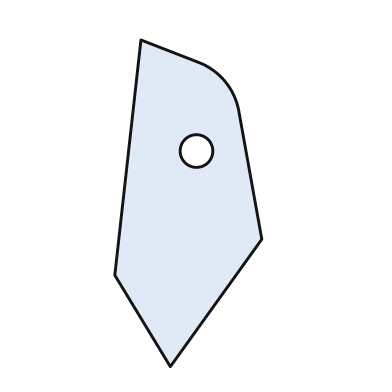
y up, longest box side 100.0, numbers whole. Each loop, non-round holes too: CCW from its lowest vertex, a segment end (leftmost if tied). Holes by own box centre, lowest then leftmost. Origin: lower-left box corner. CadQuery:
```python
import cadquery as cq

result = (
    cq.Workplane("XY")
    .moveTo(17.0, 0.0)
    .lineTo(45.0, 39.0)
    .lineTo(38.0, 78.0)
    .threePointArc((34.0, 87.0), (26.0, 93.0))
    .lineTo(8.0, 100.0)
    .lineTo(0.0, 28.0)
    .close()
    .moveTo(25.0, 66.0)
    .circle(5.0)
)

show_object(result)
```